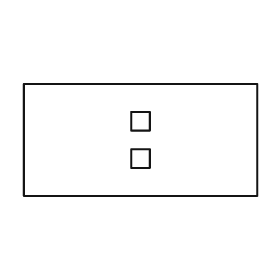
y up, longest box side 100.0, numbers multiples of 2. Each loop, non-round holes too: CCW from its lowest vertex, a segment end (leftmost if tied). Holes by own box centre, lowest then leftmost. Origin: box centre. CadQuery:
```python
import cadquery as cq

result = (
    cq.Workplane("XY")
    .moveTo(-50.0, -24.0)
    .lineTo(50.0, -24.0)
    .lineTo(50.0, 24.0)
    .lineTo(-50.0, 24.0)
    .close()
    .moveTo(-4.0, -12.0)
    .lineTo(4.0, -12.0)
    .lineTo(4.0, -4.0)
    .lineTo(-4.0, -4.0)
    .close()
    .moveTo(-4.0, 4.0)
    .lineTo(4.0, 4.0)
    .lineTo(4.0, 12.0)
    .lineTo(-4.0, 12.0)
    .close()
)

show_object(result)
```